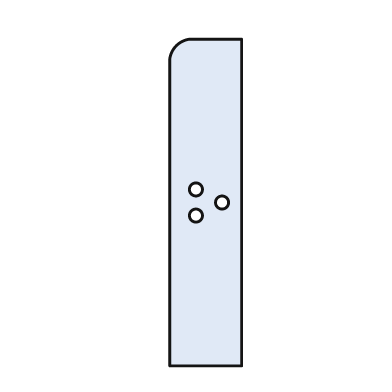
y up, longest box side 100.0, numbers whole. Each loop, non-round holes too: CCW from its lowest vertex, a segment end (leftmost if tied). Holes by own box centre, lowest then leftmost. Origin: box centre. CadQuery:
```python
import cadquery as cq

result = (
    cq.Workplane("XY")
    .moveTo(-11.0, -50.0)
    .lineTo(11.0, -50.0)
    .lineTo(11.0, 50.0)
    .lineTo(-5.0, 50.0)
    .threePointArc((-9.0, 48.0), (-11.0, 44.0))
    .close()
    .moveTo(-3.0, -4.0)
    .circle(2.0)
    .moveTo(5.0, 0.0)
    .circle(2.0)
    .moveTo(-3.0, 4.0)
    .circle(2.0)
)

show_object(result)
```